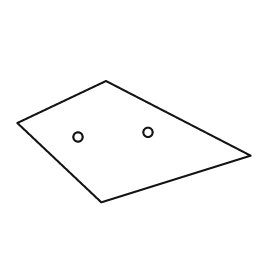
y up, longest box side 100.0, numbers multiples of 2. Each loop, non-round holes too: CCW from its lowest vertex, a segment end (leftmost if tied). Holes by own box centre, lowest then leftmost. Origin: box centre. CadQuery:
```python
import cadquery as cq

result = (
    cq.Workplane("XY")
    .moveTo(-14.0, -26.0)
    .lineTo(50.0, -6.0)
    .lineTo(-12.0, 26.0)
    .lineTo(-50.0, 8.0)
    .close()
    .moveTo(-24.0, 2.0)
    .circle(2.0)
    .moveTo(6.0, 4.0)
    .circle(2.0)
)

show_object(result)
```